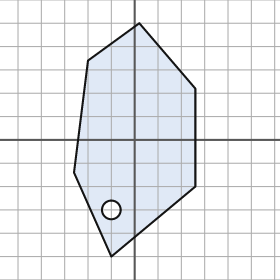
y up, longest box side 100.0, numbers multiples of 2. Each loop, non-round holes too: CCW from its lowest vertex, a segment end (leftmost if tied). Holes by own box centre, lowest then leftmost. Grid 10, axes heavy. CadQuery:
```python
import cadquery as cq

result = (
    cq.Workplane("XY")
    .moveTo(-10.0, -50.0)
    .lineTo(26.0, -20.0)
    .lineTo(26.0, 22.0)
    .lineTo(2.0, 50.0)
    .lineTo(-20.0, 34.0)
    .lineTo(-26.0, -14.0)
    .close()
    .moveTo(-10.0, -30.0)
    .circle(4.0)
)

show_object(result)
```